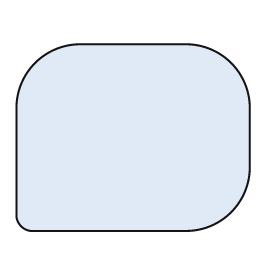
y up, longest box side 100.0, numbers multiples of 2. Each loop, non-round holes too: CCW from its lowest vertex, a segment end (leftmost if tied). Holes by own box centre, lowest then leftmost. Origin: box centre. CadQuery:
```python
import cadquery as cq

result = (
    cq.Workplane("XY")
    .moveTo(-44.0, -40.0)
    .lineTo(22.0, -40.0)
    .threePointArc((42.0, -32.0), (50.0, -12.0))
    .lineTo(50.0, 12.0)
    .threePointArc((42.0, 32.0), (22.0, 40.0))
    .lineTo(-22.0, 40.0)
    .threePointArc((-42.0, 32.0), (-50.0, 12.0))
    .lineTo(-50.0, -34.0)
    .threePointArc((-48.0, -38.0), (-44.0, -40.0))
    .close()
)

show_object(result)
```